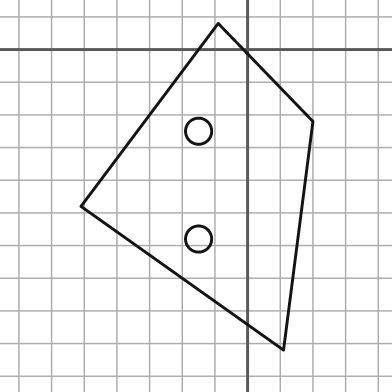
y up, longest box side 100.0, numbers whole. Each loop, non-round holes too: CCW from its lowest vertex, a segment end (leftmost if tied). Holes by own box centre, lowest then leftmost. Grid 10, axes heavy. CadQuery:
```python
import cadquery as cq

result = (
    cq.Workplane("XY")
    .moveTo(11.0, -92.0)
    .lineTo(20.0, -22.0)
    .lineTo(-9.0, 8.0)
    .lineTo(-51.0, -48.0)
    .close()
    .moveTo(-15.0, -58.0)
    .circle(4.0)
    .moveTo(-15.0, -25.0)
    .circle(4.0)
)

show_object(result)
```